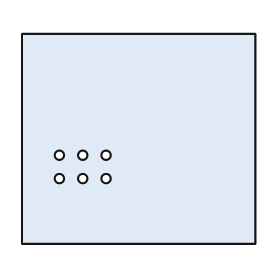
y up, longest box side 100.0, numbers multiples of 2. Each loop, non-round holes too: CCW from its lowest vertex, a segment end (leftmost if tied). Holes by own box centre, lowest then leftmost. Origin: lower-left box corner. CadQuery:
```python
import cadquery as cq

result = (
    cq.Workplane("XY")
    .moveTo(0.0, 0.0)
    .lineTo(100.0, 0.0)
    .lineTo(100.0, 90.0)
    .lineTo(0.0, 90.0)
    .close()
    .moveTo(16.0, 28.0)
    .circle(2.0)
    .moveTo(26.0, 28.0)
    .circle(2.0)
    .moveTo(36.0, 28.0)
    .circle(2.0)
    .moveTo(16.0, 38.0)
    .circle(2.0)
    .moveTo(26.0, 38.0)
    .circle(2.0)
    .moveTo(36.0, 38.0)
    .circle(2.0)
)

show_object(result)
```